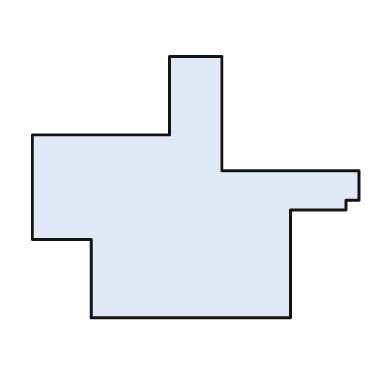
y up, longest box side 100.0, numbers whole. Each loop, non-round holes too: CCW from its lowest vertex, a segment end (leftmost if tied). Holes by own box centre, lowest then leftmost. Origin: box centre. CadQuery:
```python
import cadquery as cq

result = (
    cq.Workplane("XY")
    .moveTo(-32.0, -40.0)
    .lineTo(29.0, -40.0)
    .lineTo(29.0, -7.0)
    .lineTo(46.0, -7.0)
    .lineTo(46.0, -4.0)
    .lineTo(50.0, -4.0)
    .lineTo(50.0, 5.0)
    .lineTo(8.0, 5.0)
    .lineTo(8.0, 40.0)
    .lineTo(-8.0, 40.0)
    .lineTo(-8.0, 16.0)
    .lineTo(-50.0, 16.0)
    .lineTo(-50.0, -16.0)
    .lineTo(-32.0, -16.0)
    .close()
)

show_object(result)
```